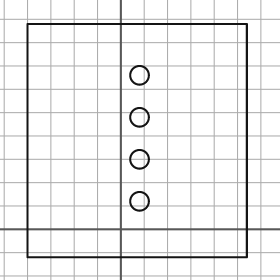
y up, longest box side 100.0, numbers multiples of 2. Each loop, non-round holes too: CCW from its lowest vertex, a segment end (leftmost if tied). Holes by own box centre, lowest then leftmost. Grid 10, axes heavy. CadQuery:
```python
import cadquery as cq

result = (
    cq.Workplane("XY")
    .moveTo(-40.0, -12.0)
    .lineTo(54.0, -12.0)
    .lineTo(54.0, 88.0)
    .lineTo(-40.0, 88.0)
    .close()
    .moveTo(8.0, 12.0)
    .circle(4.0)
    .moveTo(8.0, 30.0)
    .circle(4.0)
    .moveTo(8.0, 48.0)
    .circle(4.0)
    .moveTo(8.0, 66.0)
    .circle(4.0)
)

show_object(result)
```